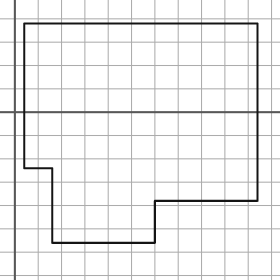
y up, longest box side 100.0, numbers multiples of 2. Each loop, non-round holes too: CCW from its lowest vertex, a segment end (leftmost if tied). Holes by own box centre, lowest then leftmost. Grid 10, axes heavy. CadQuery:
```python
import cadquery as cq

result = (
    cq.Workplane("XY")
    .moveTo(16.0, -56.0)
    .lineTo(60.0, -56.0)
    .lineTo(60.0, -38.0)
    .lineTo(104.0, -38.0)
    .lineTo(104.0, 38.0)
    .lineTo(4.0, 38.0)
    .lineTo(4.0, -24.0)
    .lineTo(16.0, -24.0)
    .close()
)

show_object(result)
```